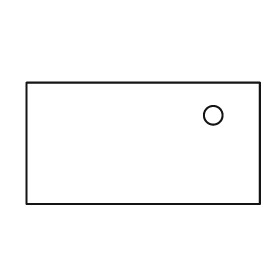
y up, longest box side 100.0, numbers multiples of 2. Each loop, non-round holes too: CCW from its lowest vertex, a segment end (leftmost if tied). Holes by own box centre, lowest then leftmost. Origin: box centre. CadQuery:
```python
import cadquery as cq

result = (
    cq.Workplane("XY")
    .moveTo(-50.0, -26.0)
    .lineTo(50.0, -26.0)
    .lineTo(50.0, 26.0)
    .lineTo(-50.0, 26.0)
    .close()
    .moveTo(30.0, 12.0)
    .circle(4.0)
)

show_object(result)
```